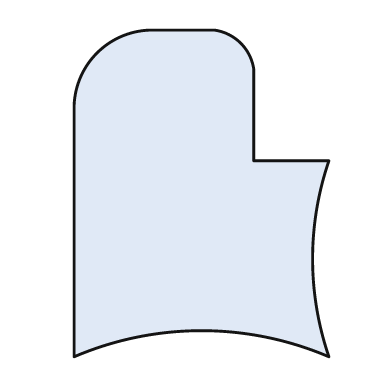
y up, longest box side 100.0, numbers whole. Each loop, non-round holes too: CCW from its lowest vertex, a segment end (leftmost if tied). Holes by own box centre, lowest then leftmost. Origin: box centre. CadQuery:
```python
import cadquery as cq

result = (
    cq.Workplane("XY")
    .moveTo(-39.0, -50.0)
    .threePointArc((0.0, -42.0), (39.0, -50.0))
    .threePointArc((34.0, -20.0), (39.0, 10.0))
    .lineTo(16.0, 10.0)
    .lineTo(16.0, 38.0)
    .threePointArc((12.0, 46.0), (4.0, 50.0))
    .lineTo(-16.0, 50.0)
    .threePointArc((-32.0, 43.0), (-39.0, 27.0))
    .close()
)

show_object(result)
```